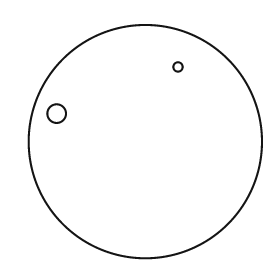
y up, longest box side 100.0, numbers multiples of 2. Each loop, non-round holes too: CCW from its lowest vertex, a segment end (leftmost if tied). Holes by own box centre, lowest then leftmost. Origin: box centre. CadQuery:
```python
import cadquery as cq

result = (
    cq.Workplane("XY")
    .moveTo(0.0, 0.0)
    .circle(50.0)
    .moveTo(-38.0, 12.0)
    .circle(4.0)
    .moveTo(14.0, 32.0)
    .circle(2.0)
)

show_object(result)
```